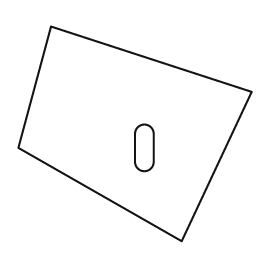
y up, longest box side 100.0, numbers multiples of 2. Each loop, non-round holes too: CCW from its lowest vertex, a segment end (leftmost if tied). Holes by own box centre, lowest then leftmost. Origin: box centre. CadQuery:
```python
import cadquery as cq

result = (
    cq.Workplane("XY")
    .moveTo(20.0, -46.0)
    .lineTo(50.0, 18.0)
    .lineTo(-36.0, 46.0)
    .lineTo(-50.0, -6.0)
    .close()
    .moveTo(0.0, -12.0)
    .threePointArc((4.0, -16.0), (8.0, -12.0))
    .lineTo(8.0, 0.0)
    .threePointArc((4.0, 4.0), (0.0, 0.0))
    .close()
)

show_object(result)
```